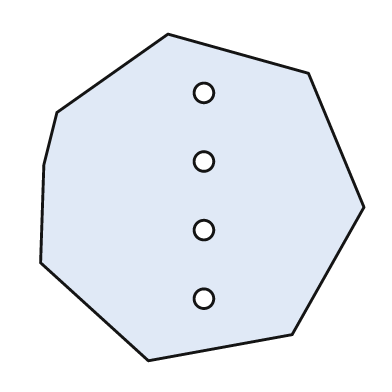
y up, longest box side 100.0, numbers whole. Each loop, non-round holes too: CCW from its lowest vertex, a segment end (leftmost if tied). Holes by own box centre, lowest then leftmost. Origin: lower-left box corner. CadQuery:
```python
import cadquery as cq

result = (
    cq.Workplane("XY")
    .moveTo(33.0, 0.0)
    .lineTo(77.0, 8.0)
    .lineTo(99.0, 47.0)
    .lineTo(82.0, 88.0)
    .lineTo(39.0, 100.0)
    .lineTo(5.0, 76.0)
    .lineTo(1.0, 60.0)
    .lineTo(0.0, 30.0)
    .close()
    .moveTo(50.0, 19.0)
    .circle(3.0)
    .moveTo(50.0, 40.0)
    .circle(3.0)
    .moveTo(50.0, 61.0)
    .circle(3.0)
    .moveTo(50.0, 82.0)
    .circle(3.0)
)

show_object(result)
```